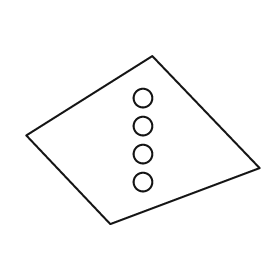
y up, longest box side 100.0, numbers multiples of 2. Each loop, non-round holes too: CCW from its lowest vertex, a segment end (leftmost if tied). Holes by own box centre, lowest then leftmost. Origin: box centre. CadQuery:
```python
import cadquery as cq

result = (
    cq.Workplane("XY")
    .moveTo(-14.0, -36.0)
    .lineTo(50.0, -12.0)
    .lineTo(4.0, 36.0)
    .lineTo(-50.0, 2.0)
    .close()
    .moveTo(0.0, -18.0)
    .circle(4.0)
    .moveTo(0.0, -6.0)
    .circle(4.0)
    .moveTo(0.0, 6.0)
    .circle(4.0)
    .moveTo(0.0, 18.0)
    .circle(4.0)
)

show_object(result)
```